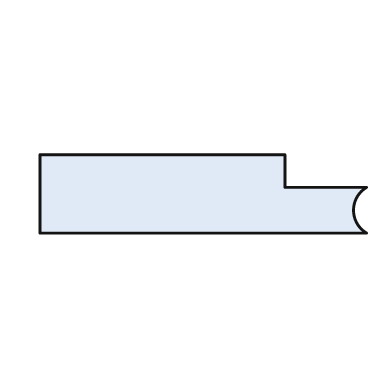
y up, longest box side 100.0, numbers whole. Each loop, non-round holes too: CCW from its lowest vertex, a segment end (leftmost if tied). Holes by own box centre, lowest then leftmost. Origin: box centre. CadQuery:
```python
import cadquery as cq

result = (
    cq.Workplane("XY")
    .moveTo(-50.0, -12.0)
    .lineTo(50.0, -12.0)
    .threePointArc((46.0, -5.0), (50.0, 2.0))
    .lineTo(25.0, 2.0)
    .lineTo(25.0, 12.0)
    .lineTo(-50.0, 12.0)
    .close()
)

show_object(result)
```